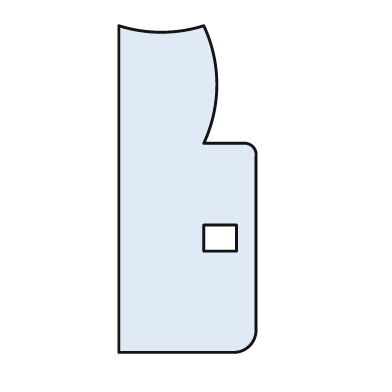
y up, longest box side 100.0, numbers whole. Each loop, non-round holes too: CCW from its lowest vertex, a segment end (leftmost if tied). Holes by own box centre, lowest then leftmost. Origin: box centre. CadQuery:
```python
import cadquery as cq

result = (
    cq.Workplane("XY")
    .moveTo(-21.0, -50.0)
    .lineTo(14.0, -50.0)
    .threePointArc((19.0, -48.0), (21.0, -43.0))
    .lineTo(21.0, 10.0)
    .threePointArc((20.0, 13.0), (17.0, 14.0))
    .lineTo(5.0, 14.0)
    .threePointArc((9.0, 32.0), (5.0, 50.0))
    .threePointArc((-8.0, 48.0), (-21.0, 50.0))
    .close()
    .moveTo(5.0, -19.0)
    .lineTo(15.0, -19.0)
    .lineTo(15.0, -11.0)
    .lineTo(5.0, -11.0)
    .close()
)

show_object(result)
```